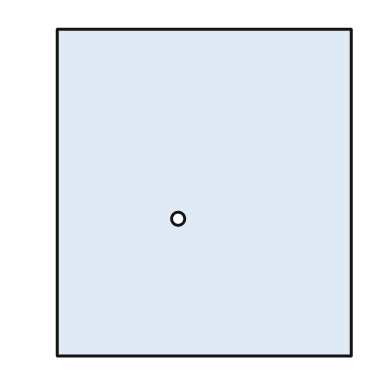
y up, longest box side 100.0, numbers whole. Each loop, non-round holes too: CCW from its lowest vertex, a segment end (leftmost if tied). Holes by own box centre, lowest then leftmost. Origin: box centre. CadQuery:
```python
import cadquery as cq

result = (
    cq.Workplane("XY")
    .moveTo(-45.0, -50.0)
    .lineTo(45.0, -50.0)
    .lineTo(45.0, 50.0)
    .lineTo(-45.0, 50.0)
    .close()
    .moveTo(-8.0, -8.0)
    .circle(2.0)
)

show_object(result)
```